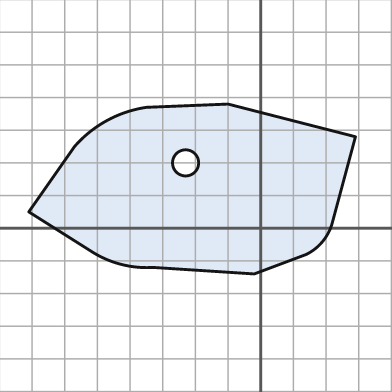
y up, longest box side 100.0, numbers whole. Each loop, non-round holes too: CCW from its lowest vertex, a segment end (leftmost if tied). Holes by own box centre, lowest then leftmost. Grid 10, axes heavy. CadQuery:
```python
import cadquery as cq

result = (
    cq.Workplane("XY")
    .moveTo(-2.0, -14.0)
    .lineTo(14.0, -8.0)
    .threePointArc((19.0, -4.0), (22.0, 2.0))
    .lineTo(29.0, 28.0)
    .lineTo(-10.0, 38.0)
    .lineTo(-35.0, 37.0)
    .threePointArc((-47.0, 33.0), (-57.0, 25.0))
    .lineTo(-71.0, 5.0)
    .lineTo(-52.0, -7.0)
    .threePointArc((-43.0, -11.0), (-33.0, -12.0))
    .close()
    .moveTo(-23.0, 20.0)
    .circle(4.0)
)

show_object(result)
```